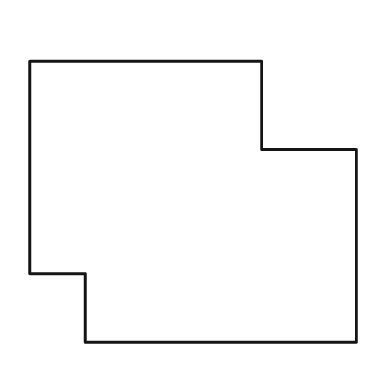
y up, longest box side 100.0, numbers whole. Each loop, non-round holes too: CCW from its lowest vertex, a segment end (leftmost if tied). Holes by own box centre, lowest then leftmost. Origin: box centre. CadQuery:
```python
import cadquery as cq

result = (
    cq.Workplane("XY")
    .moveTo(-33.0, -43.0)
    .lineTo(50.0, -43.0)
    .lineTo(50.0, 16.0)
    .lineTo(21.0, 16.0)
    .lineTo(21.0, 43.0)
    .lineTo(-50.0, 43.0)
    .lineTo(-50.0, -22.0)
    .lineTo(-33.0, -22.0)
    .close()
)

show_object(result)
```